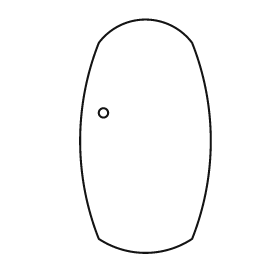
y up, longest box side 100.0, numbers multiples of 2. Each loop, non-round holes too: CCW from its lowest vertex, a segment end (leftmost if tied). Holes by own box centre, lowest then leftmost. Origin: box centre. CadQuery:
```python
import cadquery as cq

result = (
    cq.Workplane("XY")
    .moveTo(-20.0, -44.0)
    .threePointArc((0.0, -50.0), (20.0, -44.0))
    .threePointArc((28.0, -2.0), (20.0, 40.0))
    .threePointArc((0.0, 50.0), (-20.0, 40.0))
    .threePointArc((-28.0, -2.0), (-20.0, -44.0))
    .close()
    .moveTo(-18.0, 10.0)
    .circle(2.0)
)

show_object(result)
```